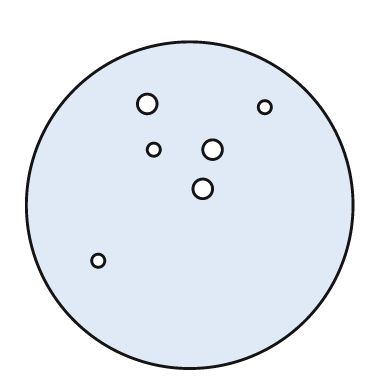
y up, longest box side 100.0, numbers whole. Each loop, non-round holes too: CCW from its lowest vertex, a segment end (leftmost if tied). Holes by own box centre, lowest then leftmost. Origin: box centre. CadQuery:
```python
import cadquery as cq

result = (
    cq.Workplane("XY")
    .moveTo(0.0, 0.0)
    .circle(50.0)
    .moveTo(-28.0, -17.0)
    .circle(2.0)
    .moveTo(4.0, 5.0)
    .circle(3.0)
    .moveTo(-11.0, 17.0)
    .circle(2.0)
    .moveTo(7.0, 17.0)
    .circle(3.0)
    .moveTo(23.0, 30.0)
    .circle(2.0)
    .moveTo(-13.0, 31.0)
    .circle(3.0)
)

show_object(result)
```